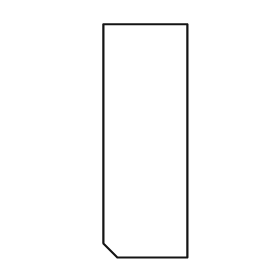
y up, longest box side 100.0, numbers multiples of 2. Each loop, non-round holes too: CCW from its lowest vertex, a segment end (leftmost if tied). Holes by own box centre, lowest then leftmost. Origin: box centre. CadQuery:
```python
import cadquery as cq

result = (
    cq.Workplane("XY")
    .moveTo(-12.0, -50.0)
    .lineTo(18.0, -50.0)
    .lineTo(18.0, 50.0)
    .lineTo(-18.0, 50.0)
    .lineTo(-18.0, -44.0)
    .close()
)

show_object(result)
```